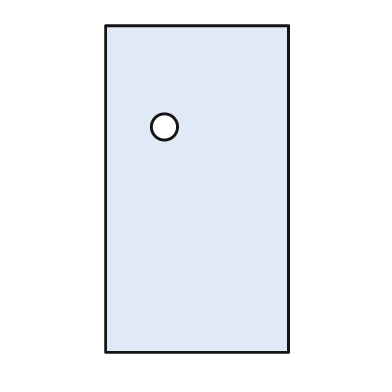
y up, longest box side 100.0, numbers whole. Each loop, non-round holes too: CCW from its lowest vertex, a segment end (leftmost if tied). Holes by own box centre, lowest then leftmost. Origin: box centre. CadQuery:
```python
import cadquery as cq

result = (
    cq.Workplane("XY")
    .moveTo(-28.0, -50.0)
    .lineTo(28.0, -50.0)
    .lineTo(28.0, 50.0)
    .lineTo(-28.0, 50.0)
    .close()
    .moveTo(-10.0, 19.0)
    .circle(4.0)
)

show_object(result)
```